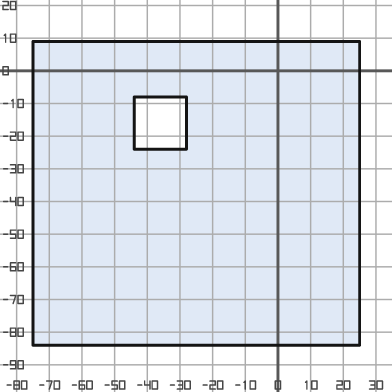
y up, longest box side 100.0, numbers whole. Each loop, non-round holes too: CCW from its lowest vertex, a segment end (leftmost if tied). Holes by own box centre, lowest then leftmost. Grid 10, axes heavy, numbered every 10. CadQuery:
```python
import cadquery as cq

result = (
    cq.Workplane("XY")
    .moveTo(-75.0, -84.0)
    .lineTo(25.0, -84.0)
    .lineTo(25.0, 9.0)
    .lineTo(-75.0, 9.0)
    .close()
    .moveTo(-44.0, -24.0)
    .lineTo(-28.0, -24.0)
    .lineTo(-28.0, -8.0)
    .lineTo(-44.0, -8.0)
    .close()
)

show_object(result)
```